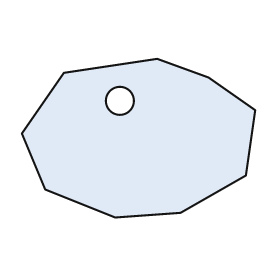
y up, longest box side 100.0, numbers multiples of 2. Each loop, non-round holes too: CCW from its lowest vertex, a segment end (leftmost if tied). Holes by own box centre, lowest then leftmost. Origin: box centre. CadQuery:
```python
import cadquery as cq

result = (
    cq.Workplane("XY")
    .moveTo(-10.0, -34.0)
    .lineTo(18.0, -32.0)
    .lineTo(46.0, -16.0)
    .lineTo(50.0, 12.0)
    .lineTo(30.0, 26.0)
    .lineTo(8.0, 34.0)
    .lineTo(-32.0, 28.0)
    .lineTo(-50.0, 2.0)
    .lineTo(-40.0, -22.0)
    .close()
    .moveTo(-8.0, 16.0)
    .circle(6.0)
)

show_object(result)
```